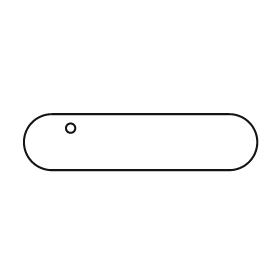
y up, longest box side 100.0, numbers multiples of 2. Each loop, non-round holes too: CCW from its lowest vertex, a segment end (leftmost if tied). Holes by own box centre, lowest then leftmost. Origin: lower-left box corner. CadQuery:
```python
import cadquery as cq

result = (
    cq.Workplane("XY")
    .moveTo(12.0, 0.0)
    .lineTo(88.0, 0.0)
    .threePointArc((100.0, 12.0), (88.0, 24.0))
    .lineTo(12.0, 24.0)
    .threePointArc((0.0, 12.0), (12.0, 0.0))
    .close()
    .moveTo(20.0, 18.0)
    .circle(2.0)
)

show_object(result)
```